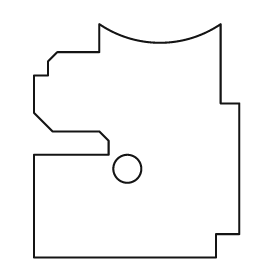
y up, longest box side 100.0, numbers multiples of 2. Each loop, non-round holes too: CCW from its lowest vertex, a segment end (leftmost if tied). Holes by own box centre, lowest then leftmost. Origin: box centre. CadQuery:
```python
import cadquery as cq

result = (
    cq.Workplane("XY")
    .moveTo(-44.0, -50.0)
    .lineTo(34.0, -50.0)
    .lineTo(34.0, -40.0)
    .lineTo(44.0, -40.0)
    .lineTo(44.0, 16.0)
    .lineTo(36.0, 16.0)
    .lineTo(36.0, 50.0)
    .threePointArc((10.0, 42.0), (-16.0, 50.0))
    .lineTo(-16.0, 38.0)
    .lineTo(-34.0, 38.0)
    .lineTo(-38.0, 34.0)
    .lineTo(-38.0, 28.0)
    .lineTo(-44.0, 28.0)
    .lineTo(-44.0, 12.0)
    .lineTo(-36.0, 4.0)
    .lineTo(-16.0, 4.0)
    .lineTo(-12.0, 0.0)
    .lineTo(-12.0, -6.0)
    .lineTo(-44.0, -6.0)
    .close()
    .moveTo(-4.0, -12.0)
    .circle(6.0)
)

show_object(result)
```